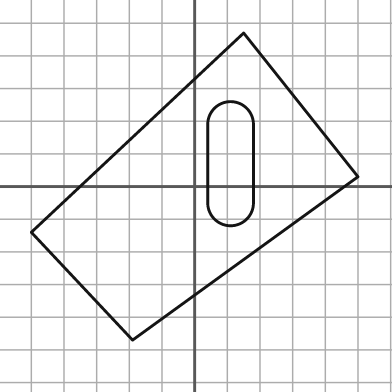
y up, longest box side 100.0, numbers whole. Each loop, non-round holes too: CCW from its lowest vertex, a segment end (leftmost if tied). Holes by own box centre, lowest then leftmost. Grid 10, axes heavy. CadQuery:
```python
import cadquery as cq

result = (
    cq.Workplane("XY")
    .moveTo(-19.0, -47.0)
    .lineTo(50.0, 3.0)
    .lineTo(15.0, 47.0)
    .lineTo(-50.0, -14.0)
    .close()
    .moveTo(4.0, -5.0)
    .threePointArc((11.0, -12.0), (18.0, -5.0))
    .lineTo(18.0, 19.0)
    .threePointArc((11.0, 26.0), (4.0, 19.0))
    .close()
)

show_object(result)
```